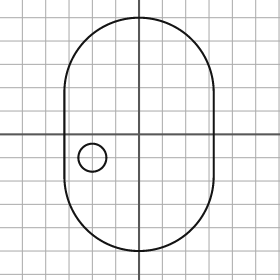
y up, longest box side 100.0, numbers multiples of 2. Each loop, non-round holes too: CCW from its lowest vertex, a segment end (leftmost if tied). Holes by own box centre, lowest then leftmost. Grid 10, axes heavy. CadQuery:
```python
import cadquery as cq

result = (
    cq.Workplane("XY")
    .moveTo(-32.0, -18.0)
    .threePointArc((0.0, -50.0), (32.0, -18.0))
    .lineTo(32.0, 18.0)
    .threePointArc((0.0, 50.0), (-32.0, 18.0))
    .close()
    .moveTo(-20.0, -10.0)
    .circle(6.0)
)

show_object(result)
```